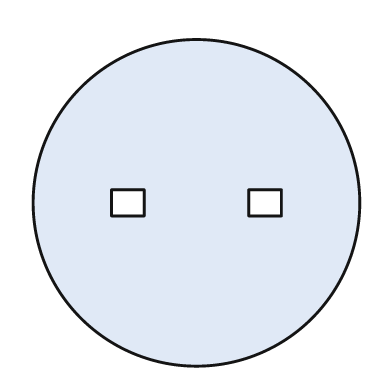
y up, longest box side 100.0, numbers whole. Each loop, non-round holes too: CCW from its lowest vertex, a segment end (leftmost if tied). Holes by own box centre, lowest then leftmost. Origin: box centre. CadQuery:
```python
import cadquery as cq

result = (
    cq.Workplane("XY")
    .moveTo(0.0, 0.0)
    .circle(50.0)
    .moveTo(-26.0, -4.0)
    .lineTo(-16.0, -4.0)
    .lineTo(-16.0, 4.0)
    .lineTo(-26.0, 4.0)
    .close()
    .moveTo(16.0, -4.0)
    .lineTo(26.0, -4.0)
    .lineTo(26.0, 4.0)
    .lineTo(16.0, 4.0)
    .close()
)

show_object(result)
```